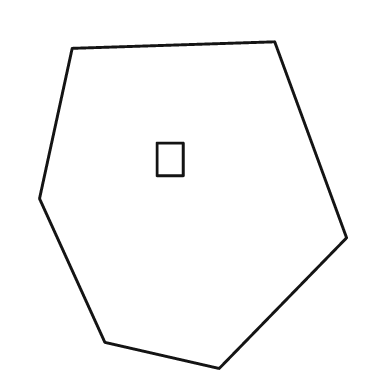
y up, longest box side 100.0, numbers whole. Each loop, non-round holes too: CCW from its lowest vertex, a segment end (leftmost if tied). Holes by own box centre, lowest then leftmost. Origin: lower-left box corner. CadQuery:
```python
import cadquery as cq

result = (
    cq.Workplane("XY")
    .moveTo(55.0, 0.0)
    .lineTo(94.0, 40.0)
    .lineTo(72.0, 100.0)
    .lineTo(10.0, 98.0)
    .lineTo(0.0, 52.0)
    .lineTo(20.0, 8.0)
    .close()
    .moveTo(36.0, 59.0)
    .lineTo(44.0, 59.0)
    .lineTo(44.0, 69.0)
    .lineTo(36.0, 69.0)
    .close()
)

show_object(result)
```